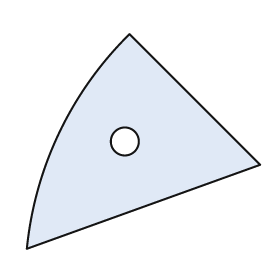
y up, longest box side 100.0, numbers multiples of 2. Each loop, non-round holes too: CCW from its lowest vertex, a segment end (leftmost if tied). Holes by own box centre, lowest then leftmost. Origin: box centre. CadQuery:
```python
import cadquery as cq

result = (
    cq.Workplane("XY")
    .moveTo(-50.0, -46.0)
    .lineTo(50.0, -10.0)
    .lineTo(-6.0, 46.0)
    .threePointArc((-36.0, 4.0), (-50.0, -46.0))
    .close()
    .moveTo(-8.0, 0.0)
    .circle(6.0)
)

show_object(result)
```